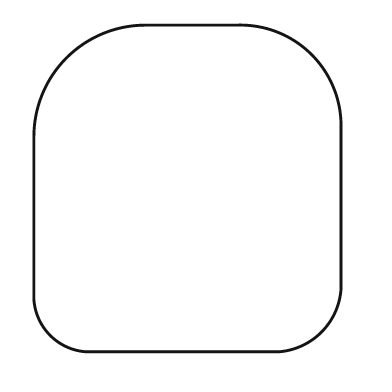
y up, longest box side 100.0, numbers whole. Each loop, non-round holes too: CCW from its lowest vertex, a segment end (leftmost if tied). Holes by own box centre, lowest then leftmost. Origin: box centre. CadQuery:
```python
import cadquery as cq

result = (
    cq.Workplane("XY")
    .moveTo(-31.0, -50.0)
    .lineTo(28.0, -50.0)
    .threePointArc((41.0, -44.0), (47.0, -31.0))
    .lineTo(47.0, 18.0)
    .threePointArc((38.0, 41.0), (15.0, 50.0))
    .lineTo(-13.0, 50.0)
    .threePointArc((-37.0, 40.0), (-47.0, 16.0))
    .lineTo(-47.0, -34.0)
    .threePointArc((-42.0, -45.0), (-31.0, -50.0))
    .close()
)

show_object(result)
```